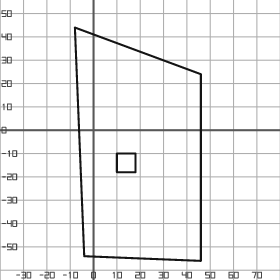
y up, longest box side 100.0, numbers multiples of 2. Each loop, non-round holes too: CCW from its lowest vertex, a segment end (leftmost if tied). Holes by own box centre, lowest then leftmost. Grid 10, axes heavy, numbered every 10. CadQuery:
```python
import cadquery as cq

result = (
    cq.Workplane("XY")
    .moveTo(46.0, -56.0)
    .lineTo(46.0, 24.0)
    .lineTo(-8.0, 44.0)
    .lineTo(-4.0, -54.0)
    .close()
    .moveTo(10.0, -18.0)
    .lineTo(18.0, -18.0)
    .lineTo(18.0, -10.0)
    .lineTo(10.0, -10.0)
    .close()
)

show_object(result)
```